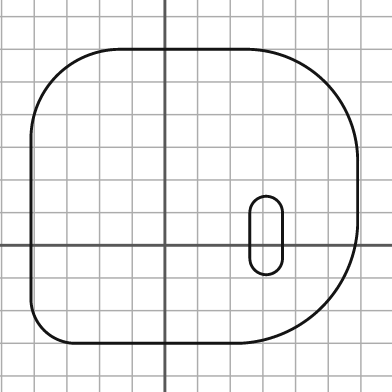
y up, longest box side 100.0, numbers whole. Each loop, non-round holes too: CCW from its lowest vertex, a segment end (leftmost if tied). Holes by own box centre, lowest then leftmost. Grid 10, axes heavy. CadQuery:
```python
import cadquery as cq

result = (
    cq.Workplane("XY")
    .moveTo(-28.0, -30.0)
    .lineTo(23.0, -30.0)
    .threePointArc((48.0, -19.0), (59.0, 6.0))
    .lineTo(59.0, 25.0)
    .threePointArc((49.0, 50.0), (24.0, 60.0))
    .lineTo(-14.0, 60.0)
    .threePointArc((-33.0, 52.0), (-41.0, 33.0))
    .lineTo(-41.0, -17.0)
    .threePointArc((-37.0, -26.0), (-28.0, -30.0))
    .close()
    .moveTo(26.0, -4.0)
    .threePointArc((31.0, -9.0), (36.0, -4.0))
    .lineTo(36.0, 10.0)
    .threePointArc((31.0, 15.0), (26.0, 10.0))
    .close()
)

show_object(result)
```